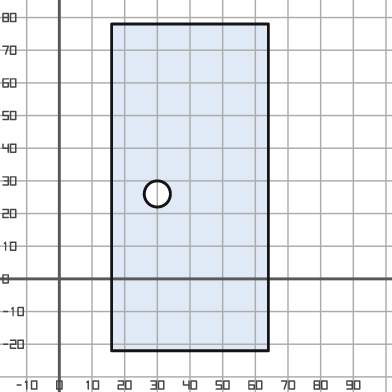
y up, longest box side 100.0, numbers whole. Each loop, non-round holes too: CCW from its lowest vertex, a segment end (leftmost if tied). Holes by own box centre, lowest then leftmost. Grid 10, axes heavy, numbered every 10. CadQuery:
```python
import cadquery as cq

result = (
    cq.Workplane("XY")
    .moveTo(16.0, -22.0)
    .lineTo(64.0, -22.0)
    .lineTo(64.0, 78.0)
    .lineTo(16.0, 78.0)
    .close()
    .moveTo(30.0, 26.0)
    .circle(4.0)
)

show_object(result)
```